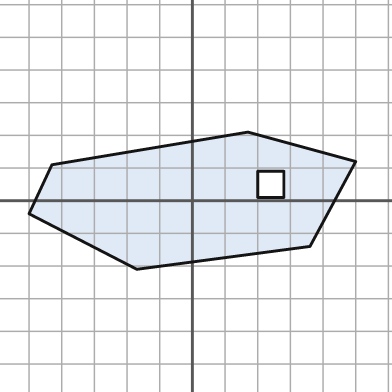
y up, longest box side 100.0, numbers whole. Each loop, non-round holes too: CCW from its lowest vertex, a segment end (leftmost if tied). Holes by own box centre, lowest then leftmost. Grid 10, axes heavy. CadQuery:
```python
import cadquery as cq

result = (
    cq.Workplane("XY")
    .moveTo(-17.0, -21.0)
    .lineTo(36.0, -14.0)
    .lineTo(50.0, 12.0)
    .lineTo(17.0, 21.0)
    .lineTo(-43.0, 11.0)
    .lineTo(-50.0, -4.0)
    .close()
    .moveTo(20.0, 1.0)
    .lineTo(28.0, 1.0)
    .lineTo(28.0, 9.0)
    .lineTo(20.0, 9.0)
    .close()
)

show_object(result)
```